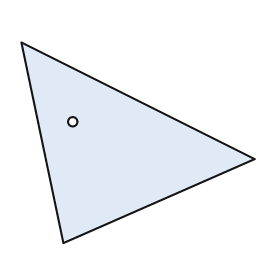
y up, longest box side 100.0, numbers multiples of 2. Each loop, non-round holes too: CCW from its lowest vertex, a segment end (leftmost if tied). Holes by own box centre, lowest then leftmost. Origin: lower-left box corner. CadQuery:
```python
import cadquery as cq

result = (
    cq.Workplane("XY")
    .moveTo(18.0, 0.0)
    .lineTo(100.0, 36.0)
    .lineTo(0.0, 86.0)
    .close()
    .moveTo(22.0, 52.0)
    .circle(2.0)
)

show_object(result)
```